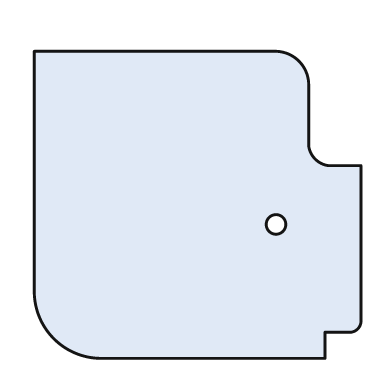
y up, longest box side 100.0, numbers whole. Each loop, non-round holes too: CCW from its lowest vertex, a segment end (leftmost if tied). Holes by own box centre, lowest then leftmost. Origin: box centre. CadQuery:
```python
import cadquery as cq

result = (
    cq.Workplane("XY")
    .moveTo(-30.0, -47.0)
    .lineTo(39.0, -47.0)
    .lineTo(39.0, -39.0)
    .lineTo(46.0, -39.0)
    .threePointArc((49.0, -38.0), (50.0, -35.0))
    .lineTo(50.0, 12.0)
    .lineTo(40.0, 12.0)
    .threePointArc((36.0, 14.0), (34.0, 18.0))
    .lineTo(34.0, 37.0)
    .threePointArc((31.0, 44.0), (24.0, 47.0))
    .lineTo(-50.0, 47.0)
    .lineTo(-50.0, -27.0)
    .threePointArc((-44.0, -41.0), (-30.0, -47.0))
    .close()
    .moveTo(24.0, -6.0)
    .circle(3.0)
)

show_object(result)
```